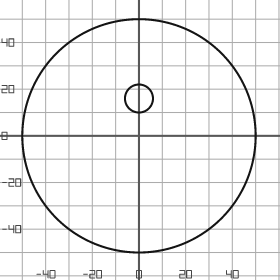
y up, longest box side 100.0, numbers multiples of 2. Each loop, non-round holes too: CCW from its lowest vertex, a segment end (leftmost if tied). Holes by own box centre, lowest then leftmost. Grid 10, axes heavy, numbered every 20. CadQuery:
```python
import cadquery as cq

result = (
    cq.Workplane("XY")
    .moveTo(0.0, 0.0)
    .circle(50.0)
    .moveTo(0.0, 16.0)
    .circle(6.0)
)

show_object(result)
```